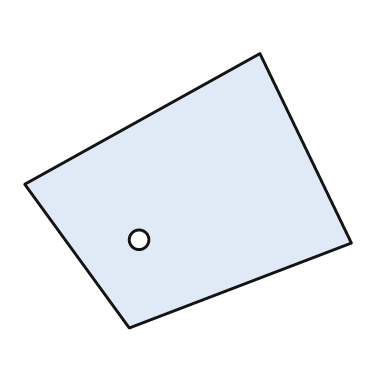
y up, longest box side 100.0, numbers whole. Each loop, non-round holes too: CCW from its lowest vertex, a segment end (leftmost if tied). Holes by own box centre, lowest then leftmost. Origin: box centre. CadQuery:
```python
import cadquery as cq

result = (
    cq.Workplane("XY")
    .moveTo(-18.0, -42.0)
    .lineTo(50.0, -16.0)
    .lineTo(22.0, 42.0)
    .lineTo(-50.0, 2.0)
    .close()
    .moveTo(-15.0, -15.0)
    .circle(3.0)
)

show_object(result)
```